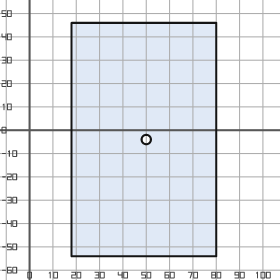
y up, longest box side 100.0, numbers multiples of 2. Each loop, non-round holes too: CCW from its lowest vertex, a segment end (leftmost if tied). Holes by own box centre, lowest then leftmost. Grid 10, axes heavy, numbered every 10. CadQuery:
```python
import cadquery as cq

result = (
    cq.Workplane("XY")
    .moveTo(18.0, -54.0)
    .lineTo(80.0, -54.0)
    .lineTo(80.0, 46.0)
    .lineTo(18.0, 46.0)
    .close()
    .moveTo(50.0, -4.0)
    .circle(2.0)
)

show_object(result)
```